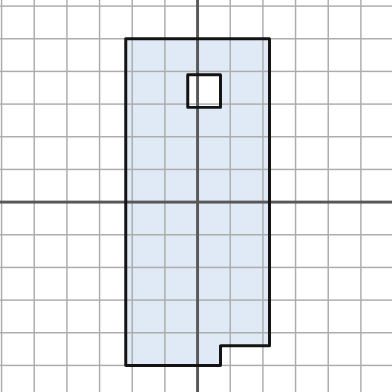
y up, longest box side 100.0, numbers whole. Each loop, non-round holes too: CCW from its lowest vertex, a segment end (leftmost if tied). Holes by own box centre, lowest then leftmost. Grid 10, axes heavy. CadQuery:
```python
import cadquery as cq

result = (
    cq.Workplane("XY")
    .moveTo(-22.0, -50.0)
    .lineTo(7.0, -50.0)
    .lineTo(7.0, -44.0)
    .lineTo(22.0, -44.0)
    .lineTo(22.0, 50.0)
    .lineTo(-22.0, 50.0)
    .close()
    .moveTo(-3.0, 29.0)
    .lineTo(7.0, 29.0)
    .lineTo(7.0, 39.0)
    .lineTo(-3.0, 39.0)
    .close()
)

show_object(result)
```